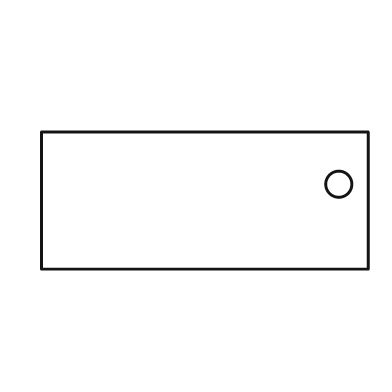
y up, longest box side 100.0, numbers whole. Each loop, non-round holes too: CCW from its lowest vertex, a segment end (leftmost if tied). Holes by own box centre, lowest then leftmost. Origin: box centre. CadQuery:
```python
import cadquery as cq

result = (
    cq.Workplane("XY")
    .moveTo(-50.0, -21.0)
    .lineTo(50.0, -21.0)
    .lineTo(50.0, 21.0)
    .lineTo(-50.0, 21.0)
    .close()
    .moveTo(41.0, 5.0)
    .circle(4.0)
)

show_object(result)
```